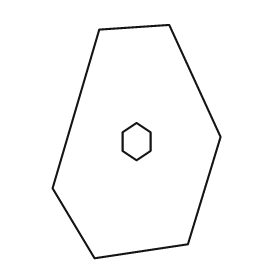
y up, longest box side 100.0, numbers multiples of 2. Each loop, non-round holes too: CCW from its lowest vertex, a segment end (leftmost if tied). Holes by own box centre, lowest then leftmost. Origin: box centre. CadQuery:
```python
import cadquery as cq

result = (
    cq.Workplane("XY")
    .moveTo(-18.0, -50.0)
    .lineTo(22.0, -44.0)
    .lineTo(36.0, 2.0)
    .lineTo(14.0, 50.0)
    .lineTo(-16.0, 48.0)
    .lineTo(-36.0, -20.0)
    .close()
    .moveTo(0.0, -8.0)
    .lineTo(6.0, -4.0)
    .lineTo(6.0, 4.0)
    .lineTo(0.0, 8.0)
    .lineTo(-6.0, 4.0)
    .lineTo(-6.0, -4.0)
    .close()
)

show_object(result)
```